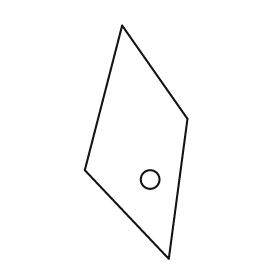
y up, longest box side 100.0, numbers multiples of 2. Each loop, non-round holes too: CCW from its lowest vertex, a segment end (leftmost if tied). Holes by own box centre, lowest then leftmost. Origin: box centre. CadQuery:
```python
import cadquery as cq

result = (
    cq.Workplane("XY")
    .moveTo(14.0, -50.0)
    .lineTo(22.0, 10.0)
    .lineTo(-6.0, 50.0)
    .lineTo(-22.0, -12.0)
    .close()
    .moveTo(6.0, -16.0)
    .circle(4.0)
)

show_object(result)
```